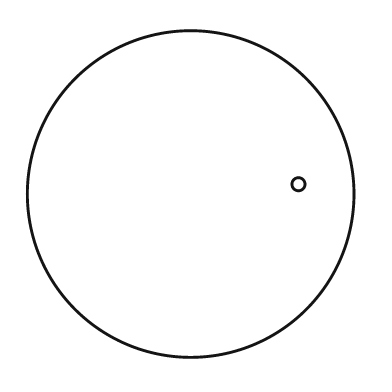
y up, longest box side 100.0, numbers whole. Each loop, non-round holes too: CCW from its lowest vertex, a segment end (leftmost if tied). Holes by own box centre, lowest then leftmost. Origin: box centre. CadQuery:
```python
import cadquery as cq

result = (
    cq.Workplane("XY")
    .moveTo(0.0, 0.0)
    .circle(50.0)
    .moveTo(33.0, 3.0)
    .circle(2.0)
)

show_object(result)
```